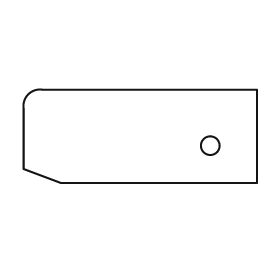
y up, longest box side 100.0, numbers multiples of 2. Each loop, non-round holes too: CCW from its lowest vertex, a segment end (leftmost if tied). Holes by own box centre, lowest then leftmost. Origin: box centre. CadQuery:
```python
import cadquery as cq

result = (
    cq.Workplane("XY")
    .moveTo(-34.0, -20.0)
    .lineTo(50.0, -20.0)
    .lineTo(50.0, 20.0)
    .lineTo(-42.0, 20.0)
    .threePointArc((-48.0, 18.0), (-50.0, 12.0))
    .lineTo(-50.0, -14.0)
    .close()
    .moveTo(30.0, -4.0)
    .circle(4.0)
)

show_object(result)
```